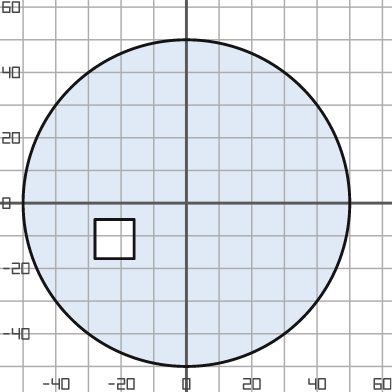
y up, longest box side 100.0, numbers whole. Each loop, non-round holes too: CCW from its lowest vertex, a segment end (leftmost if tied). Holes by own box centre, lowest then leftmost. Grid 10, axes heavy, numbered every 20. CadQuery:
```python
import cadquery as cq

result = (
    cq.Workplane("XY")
    .moveTo(0.0, 0.0)
    .circle(50.0)
    .moveTo(-28.0, -17.0)
    .lineTo(-16.0, -17.0)
    .lineTo(-16.0, -5.0)
    .lineTo(-28.0, -5.0)
    .close()
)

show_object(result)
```